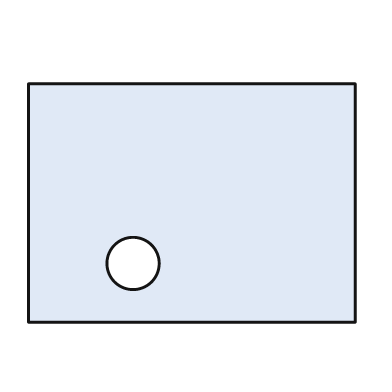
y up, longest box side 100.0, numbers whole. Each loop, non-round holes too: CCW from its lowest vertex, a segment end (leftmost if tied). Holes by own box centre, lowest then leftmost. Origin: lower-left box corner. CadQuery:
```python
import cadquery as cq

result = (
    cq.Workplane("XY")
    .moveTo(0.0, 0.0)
    .lineTo(100.0, 0.0)
    .lineTo(100.0, 73.0)
    .lineTo(0.0, 73.0)
    .close()
    .moveTo(32.0, 18.0)
    .circle(8.0)
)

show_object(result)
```